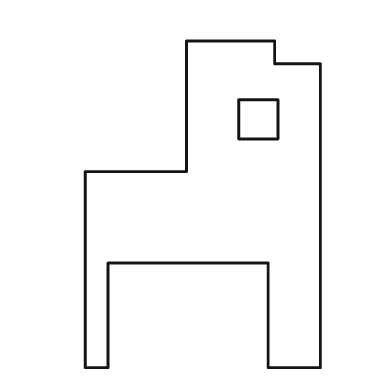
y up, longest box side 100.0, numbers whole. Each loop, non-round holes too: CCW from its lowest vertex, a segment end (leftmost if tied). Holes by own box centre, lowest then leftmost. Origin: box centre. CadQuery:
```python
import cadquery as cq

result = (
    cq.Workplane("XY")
    .moveTo(-36.0, -50.0)
    .lineTo(-29.0, -50.0)
    .lineTo(-29.0, -18.0)
    .lineTo(20.0, -18.0)
    .lineTo(20.0, -50.0)
    .lineTo(36.0, -50.0)
    .lineTo(36.0, 43.0)
    .lineTo(22.0, 43.0)
    .lineTo(22.0, 50.0)
    .lineTo(-5.0, 50.0)
    .lineTo(-5.0, 10.0)
    .lineTo(-36.0, 10.0)
    .close()
    .moveTo(11.0, 20.0)
    .lineTo(23.0, 20.0)
    .lineTo(23.0, 32.0)
    .lineTo(11.0, 32.0)
    .close()
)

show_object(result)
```